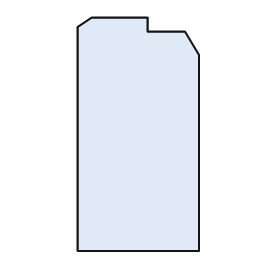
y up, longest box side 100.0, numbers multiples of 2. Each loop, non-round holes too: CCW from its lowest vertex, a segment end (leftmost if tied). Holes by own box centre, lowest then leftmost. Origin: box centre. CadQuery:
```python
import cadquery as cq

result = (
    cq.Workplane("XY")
    .moveTo(-26.0, -50.0)
    .lineTo(26.0, -50.0)
    .lineTo(26.0, 34.0)
    .lineTo(20.0, 44.0)
    .lineTo(4.0, 44.0)
    .lineTo(4.0, 50.0)
    .lineTo(-20.0, 50.0)
    .lineTo(-26.0, 46.0)
    .close()
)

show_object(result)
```